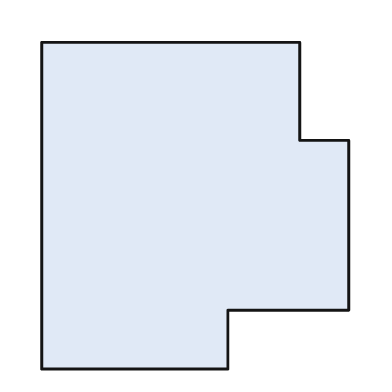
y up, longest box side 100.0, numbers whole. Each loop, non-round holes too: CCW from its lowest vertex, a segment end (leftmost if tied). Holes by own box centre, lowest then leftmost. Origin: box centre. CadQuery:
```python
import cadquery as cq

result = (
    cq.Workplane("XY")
    .moveTo(-47.0, -50.0)
    .lineTo(10.0, -50.0)
    .lineTo(10.0, -32.0)
    .lineTo(47.0, -32.0)
    .lineTo(47.0, 20.0)
    .lineTo(32.0, 20.0)
    .lineTo(32.0, 50.0)
    .lineTo(-47.0, 50.0)
    .close()
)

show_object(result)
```